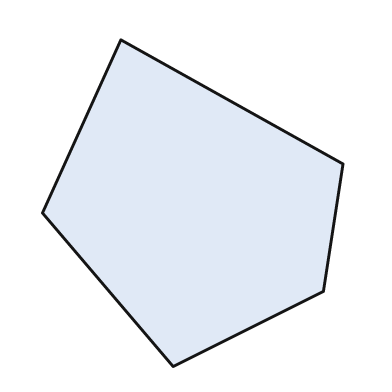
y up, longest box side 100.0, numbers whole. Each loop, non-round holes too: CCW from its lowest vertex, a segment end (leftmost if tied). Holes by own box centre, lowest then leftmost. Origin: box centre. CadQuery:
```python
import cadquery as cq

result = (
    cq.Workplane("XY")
    .moveTo(-6.0, -50.0)
    .lineTo(40.0, -27.0)
    .lineTo(46.0, 12.0)
    .lineTo(-22.0, 50.0)
    .lineTo(-46.0, -3.0)
    .close()
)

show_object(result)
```